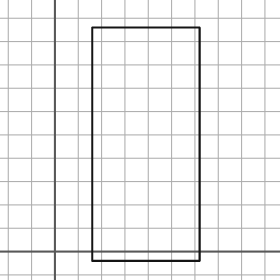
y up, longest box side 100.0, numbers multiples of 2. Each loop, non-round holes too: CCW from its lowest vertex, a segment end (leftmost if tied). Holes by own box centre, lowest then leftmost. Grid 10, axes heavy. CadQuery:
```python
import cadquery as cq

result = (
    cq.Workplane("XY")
    .moveTo(16.0, -4.0)
    .lineTo(62.0, -4.0)
    .lineTo(62.0, 96.0)
    .lineTo(16.0, 96.0)
    .close()
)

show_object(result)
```